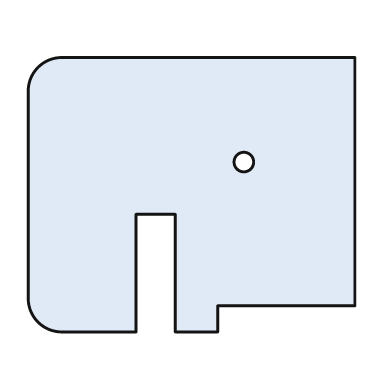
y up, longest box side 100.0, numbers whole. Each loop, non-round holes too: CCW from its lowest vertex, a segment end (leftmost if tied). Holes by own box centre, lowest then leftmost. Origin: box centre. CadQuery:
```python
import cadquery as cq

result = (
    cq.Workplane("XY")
    .moveTo(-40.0, -42.0)
    .lineTo(-17.0, -42.0)
    .lineTo(-17.0, -6.0)
    .lineTo(-5.0, -6.0)
    .lineTo(-5.0, -42.0)
    .lineTo(8.0, -42.0)
    .lineTo(8.0, -34.0)
    .lineTo(50.0, -34.0)
    .lineTo(50.0, 42.0)
    .lineTo(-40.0, 42.0)
    .threePointArc((-47.0, 39.0), (-50.0, 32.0))
    .lineTo(-50.0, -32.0)
    .threePointArc((-47.0, -39.0), (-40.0, -42.0))
    .close()
    .moveTo(16.0, 10.0)
    .circle(3.0)
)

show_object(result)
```